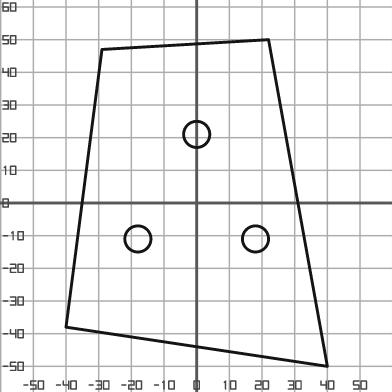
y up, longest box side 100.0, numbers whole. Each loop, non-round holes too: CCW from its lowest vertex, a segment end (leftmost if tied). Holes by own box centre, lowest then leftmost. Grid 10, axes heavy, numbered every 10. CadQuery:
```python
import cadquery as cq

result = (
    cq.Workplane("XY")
    .moveTo(40.0, -50.0)
    .lineTo(22.0, 50.0)
    .lineTo(-29.0, 47.0)
    .lineTo(-40.0, -38.0)
    .close()
    .moveTo(-18.0, -11.0)
    .circle(4.0)
    .moveTo(18.0, -11.0)
    .circle(4.0)
    .moveTo(0.0, 21.0)
    .circle(4.0)
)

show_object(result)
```